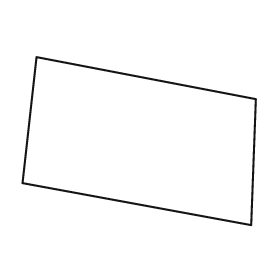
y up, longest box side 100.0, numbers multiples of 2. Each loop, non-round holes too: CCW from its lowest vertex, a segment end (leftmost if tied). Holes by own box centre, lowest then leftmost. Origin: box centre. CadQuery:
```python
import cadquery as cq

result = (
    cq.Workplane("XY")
    .moveTo(48.0, -36.0)
    .lineTo(50.0, 18.0)
    .lineTo(-44.0, 36.0)
    .lineTo(-50.0, -18.0)
    .close()
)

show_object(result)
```